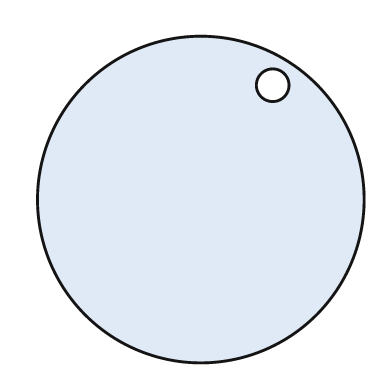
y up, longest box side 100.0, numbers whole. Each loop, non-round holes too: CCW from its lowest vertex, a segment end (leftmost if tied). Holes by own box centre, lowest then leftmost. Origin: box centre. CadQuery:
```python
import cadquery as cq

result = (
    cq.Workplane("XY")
    .moveTo(0.0, 0.0)
    .circle(50.0)
    .moveTo(22.0, 35.0)
    .circle(5.0)
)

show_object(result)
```